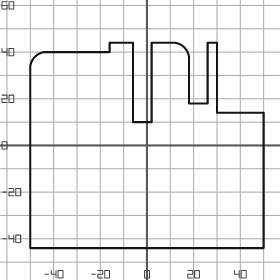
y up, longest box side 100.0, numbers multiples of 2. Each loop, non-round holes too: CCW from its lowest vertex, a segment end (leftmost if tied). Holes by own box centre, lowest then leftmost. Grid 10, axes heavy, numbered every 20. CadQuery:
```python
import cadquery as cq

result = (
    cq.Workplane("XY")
    .moveTo(-50.0, -44.0)
    .lineTo(50.0, -44.0)
    .lineTo(50.0, 14.0)
    .lineTo(30.0, 14.0)
    .lineTo(30.0, 44.0)
    .lineTo(26.0, 44.0)
    .lineTo(26.0, 18.0)
    .lineTo(18.0, 18.0)
    .lineTo(18.0, 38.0)
    .threePointArc((16.0, 42.0), (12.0, 44.0))
    .lineTo(2.0, 44.0)
    .lineTo(2.0, 10.0)
    .lineTo(-6.0, 10.0)
    .lineTo(-6.0, 44.0)
    .lineTo(-16.0, 44.0)
    .lineTo(-16.0, 40.0)
    .lineTo(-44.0, 40.0)
    .threePointArc((-48.0, 38.0), (-50.0, 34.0))
    .close()
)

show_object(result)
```